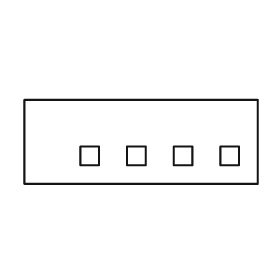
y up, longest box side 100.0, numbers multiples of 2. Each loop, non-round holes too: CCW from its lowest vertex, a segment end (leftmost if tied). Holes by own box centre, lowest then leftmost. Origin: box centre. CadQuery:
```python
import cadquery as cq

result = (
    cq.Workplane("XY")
    .moveTo(-50.0, -18.0)
    .lineTo(50.0, -18.0)
    .lineTo(50.0, 18.0)
    .lineTo(-50.0, 18.0)
    .close()
    .moveTo(-26.0, -10.0)
    .lineTo(-18.0, -10.0)
    .lineTo(-18.0, -2.0)
    .lineTo(-26.0, -2.0)
    .close()
    .moveTo(-6.0, -10.0)
    .lineTo(2.0, -10.0)
    .lineTo(2.0, -2.0)
    .lineTo(-6.0, -2.0)
    .close()
    .moveTo(14.0, -10.0)
    .lineTo(22.0, -10.0)
    .lineTo(22.0, -2.0)
    .lineTo(14.0, -2.0)
    .close()
    .moveTo(34.0, -10.0)
    .lineTo(42.0, -10.0)
    .lineTo(42.0, -2.0)
    .lineTo(34.0, -2.0)
    .close()
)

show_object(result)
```